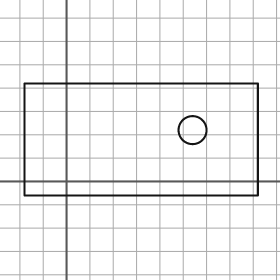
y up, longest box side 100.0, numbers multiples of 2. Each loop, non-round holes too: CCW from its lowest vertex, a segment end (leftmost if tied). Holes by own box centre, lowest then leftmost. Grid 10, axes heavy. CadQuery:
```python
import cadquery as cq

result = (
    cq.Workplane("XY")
    .moveTo(-18.0, -6.0)
    .lineTo(82.0, -6.0)
    .lineTo(82.0, 42.0)
    .lineTo(-18.0, 42.0)
    .close()
    .moveTo(54.0, 22.0)
    .circle(6.0)
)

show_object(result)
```